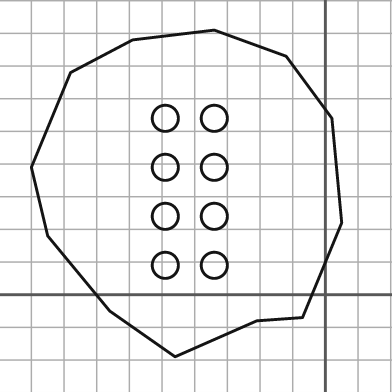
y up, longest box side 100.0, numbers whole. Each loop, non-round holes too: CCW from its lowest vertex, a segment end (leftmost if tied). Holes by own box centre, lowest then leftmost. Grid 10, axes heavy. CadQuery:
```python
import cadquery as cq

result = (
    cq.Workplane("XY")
    .moveTo(-46.0, -19.0)
    .lineTo(-21.0, -8.0)
    .lineTo(-7.0, -7.0)
    .lineTo(5.0, 22.0)
    .lineTo(2.0, 54.0)
    .lineTo(-12.0, 73.0)
    .lineTo(-34.0, 81.0)
    .lineTo(-59.0, 78.0)
    .lineTo(-78.0, 68.0)
    .lineTo(-90.0, 39.0)
    .lineTo(-85.0, 18.0)
    .lineTo(-66.0, -5.0)
    .close()
    .moveTo(-49.0, 9.0)
    .circle(4.0)
    .moveTo(-34.0, 9.0)
    .circle(4.0)
    .moveTo(-49.0, 24.0)
    .circle(4.0)
    .moveTo(-34.0, 24.0)
    .circle(4.0)
    .moveTo(-49.0, 39.0)
    .circle(4.0)
    .moveTo(-34.0, 39.0)
    .circle(4.0)
    .moveTo(-49.0, 54.0)
    .circle(4.0)
    .moveTo(-34.0, 54.0)
    .circle(4.0)
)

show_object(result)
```